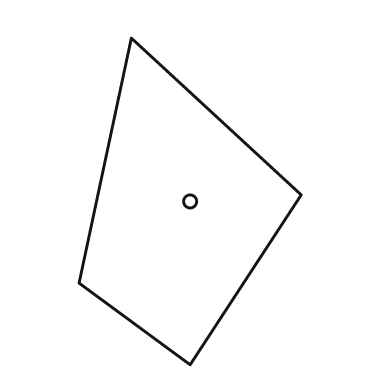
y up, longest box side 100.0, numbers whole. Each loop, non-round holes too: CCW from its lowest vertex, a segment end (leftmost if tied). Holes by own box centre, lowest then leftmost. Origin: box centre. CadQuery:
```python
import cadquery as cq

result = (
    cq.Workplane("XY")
    .moveTo(0.0, -50.0)
    .lineTo(34.0, 2.0)
    .lineTo(-18.0, 50.0)
    .lineTo(-34.0, -25.0)
    .close()
    .moveTo(0.0, 0.0)
    .circle(2.0)
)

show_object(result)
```